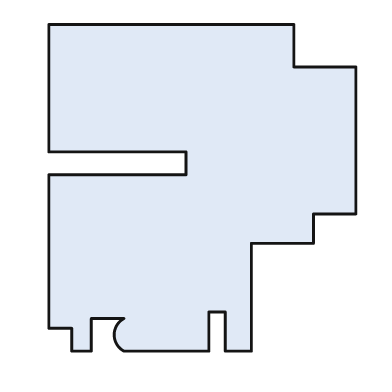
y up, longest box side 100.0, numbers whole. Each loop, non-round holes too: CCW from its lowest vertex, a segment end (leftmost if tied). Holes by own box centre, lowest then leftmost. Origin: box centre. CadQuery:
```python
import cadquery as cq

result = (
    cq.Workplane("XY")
    .moveTo(-40.0, -50.0)
    .lineTo(-34.0, -50.0)
    .lineTo(-34.0, -40.0)
    .lineTo(-24.0, -40.0)
    .threePointArc((-27.0, -45.0), (-24.0, -50.0))
    .lineTo(2.0, -50.0)
    .lineTo(2.0, -38.0)
    .lineTo(7.0, -38.0)
    .lineTo(7.0, -50.0)
    .lineTo(15.0, -50.0)
    .lineTo(15.0, -17.0)
    .lineTo(34.0, -17.0)
    .lineTo(34.0, -8.0)
    .lineTo(47.0, -8.0)
    .lineTo(47.0, 37.0)
    .lineTo(28.0, 37.0)
    .lineTo(28.0, 50.0)
    .lineTo(-47.0, 50.0)
    .lineTo(-47.0, 11.0)
    .lineTo(-5.0, 11.0)
    .lineTo(-5.0, 4.0)
    .lineTo(-47.0, 4.0)
    .lineTo(-47.0, -43.0)
    .lineTo(-40.0, -43.0)
    .close()
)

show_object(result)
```